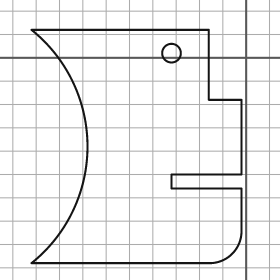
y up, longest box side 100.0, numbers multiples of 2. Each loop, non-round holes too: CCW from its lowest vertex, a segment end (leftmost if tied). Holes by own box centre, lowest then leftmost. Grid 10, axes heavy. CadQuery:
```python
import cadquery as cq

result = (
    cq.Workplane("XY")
    .moveTo(-92.0, -88.0)
    .lineTo(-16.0, -88.0)
    .threePointArc((-6.0, -84.0), (-2.0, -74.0))
    .lineTo(-2.0, -56.0)
    .lineTo(-32.0, -56.0)
    .lineTo(-32.0, -50.0)
    .lineTo(-2.0, -50.0)
    .lineTo(-2.0, -18.0)
    .lineTo(-16.0, -18.0)
    .lineTo(-16.0, 12.0)
    .lineTo(-92.0, 12.0)
    .threePointArc((-68.0, -38.0), (-92.0, -88.0))
    .close()
    .moveTo(-32.0, 2.0)
    .circle(4.0)
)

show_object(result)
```